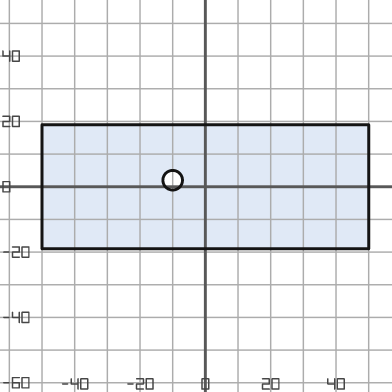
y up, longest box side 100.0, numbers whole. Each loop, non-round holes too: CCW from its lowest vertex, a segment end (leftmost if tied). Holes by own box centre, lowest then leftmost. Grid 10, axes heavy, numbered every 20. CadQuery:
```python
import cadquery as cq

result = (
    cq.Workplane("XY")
    .moveTo(-50.0, -19.0)
    .lineTo(50.0, -19.0)
    .lineTo(50.0, 19.0)
    .lineTo(-50.0, 19.0)
    .close()
    .moveTo(-10.0, 2.0)
    .circle(3.0)
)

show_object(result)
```